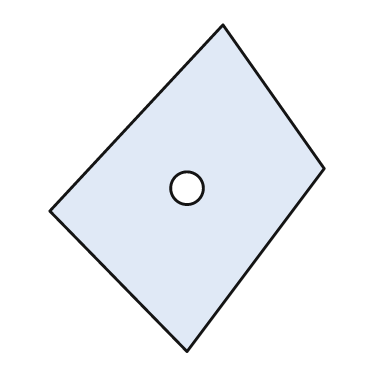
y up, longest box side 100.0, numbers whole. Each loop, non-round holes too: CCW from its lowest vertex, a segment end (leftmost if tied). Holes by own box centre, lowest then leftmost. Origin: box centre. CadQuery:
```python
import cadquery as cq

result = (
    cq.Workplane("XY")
    .moveTo(0.0, -50.0)
    .lineTo(42.0, 6.0)
    .lineTo(11.0, 50.0)
    .lineTo(-42.0, -7.0)
    .close()
    .moveTo(0.0, 0.0)
    .circle(5.0)
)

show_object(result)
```